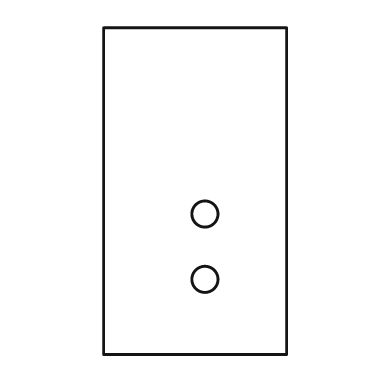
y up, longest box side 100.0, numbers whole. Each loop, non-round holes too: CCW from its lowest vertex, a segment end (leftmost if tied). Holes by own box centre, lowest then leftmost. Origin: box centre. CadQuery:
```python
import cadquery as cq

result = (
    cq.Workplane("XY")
    .moveTo(-28.0, -50.0)
    .lineTo(28.0, -50.0)
    .lineTo(28.0, 50.0)
    .lineTo(-28.0, 50.0)
    .close()
    .moveTo(3.0, -27.0)
    .circle(4.0)
    .moveTo(3.0, -7.0)
    .circle(4.0)
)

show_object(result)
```